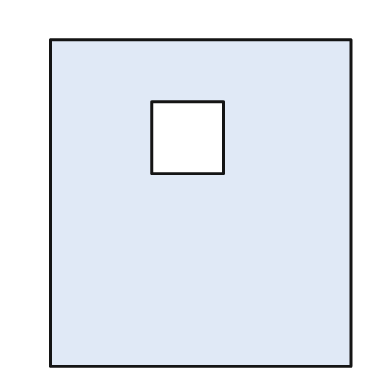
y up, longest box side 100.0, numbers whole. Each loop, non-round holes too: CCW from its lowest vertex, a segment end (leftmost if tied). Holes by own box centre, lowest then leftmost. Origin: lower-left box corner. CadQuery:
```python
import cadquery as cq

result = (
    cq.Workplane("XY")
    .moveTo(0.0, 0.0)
    .lineTo(92.0, 0.0)
    .lineTo(92.0, 100.0)
    .lineTo(0.0, 100.0)
    .close()
    .moveTo(31.0, 59.0)
    .lineTo(53.0, 59.0)
    .lineTo(53.0, 81.0)
    .lineTo(31.0, 81.0)
    .close()
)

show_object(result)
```